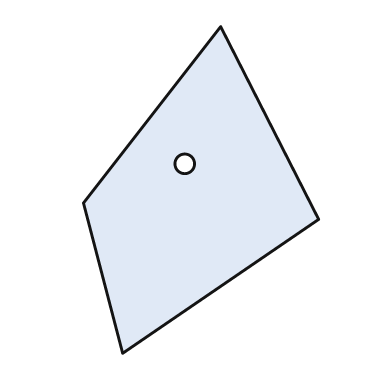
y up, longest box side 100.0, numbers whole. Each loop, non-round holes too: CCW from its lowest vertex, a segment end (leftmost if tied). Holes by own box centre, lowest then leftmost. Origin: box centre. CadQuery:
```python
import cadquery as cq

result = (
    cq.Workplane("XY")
    .moveTo(-24.0, -50.0)
    .lineTo(36.0, -9.0)
    .lineTo(6.0, 50.0)
    .lineTo(-36.0, -4.0)
    .close()
    .moveTo(-5.0, 8.0)
    .circle(3.0)
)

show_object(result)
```